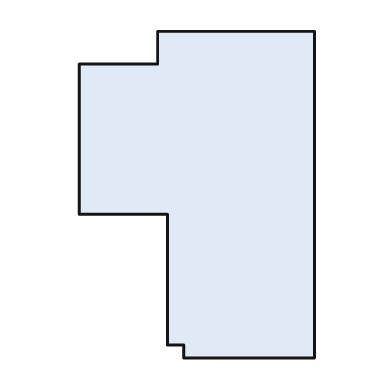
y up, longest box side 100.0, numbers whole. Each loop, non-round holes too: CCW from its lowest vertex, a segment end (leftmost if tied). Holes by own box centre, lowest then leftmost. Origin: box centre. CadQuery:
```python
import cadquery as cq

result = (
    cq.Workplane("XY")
    .moveTo(-4.0, -50.0)
    .lineTo(36.0, -50.0)
    .lineTo(36.0, 50.0)
    .lineTo(-12.0, 50.0)
    .lineTo(-12.0, 40.0)
    .lineTo(-36.0, 40.0)
    .lineTo(-36.0, -6.0)
    .lineTo(-9.0, -6.0)
    .lineTo(-9.0, -46.0)
    .lineTo(-4.0, -46.0)
    .close()
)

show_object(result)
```